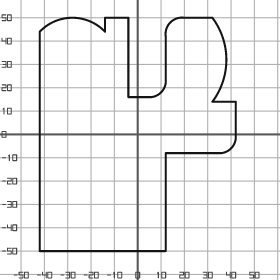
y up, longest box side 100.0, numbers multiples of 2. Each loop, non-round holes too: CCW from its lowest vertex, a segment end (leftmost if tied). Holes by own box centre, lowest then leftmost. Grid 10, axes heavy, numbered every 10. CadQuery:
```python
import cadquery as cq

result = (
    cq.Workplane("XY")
    .moveTo(-42.0, -50.0)
    .lineTo(12.0, -50.0)
    .lineTo(12.0, -8.0)
    .lineTo(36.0, -8.0)
    .threePointArc((40.0, -6.0), (42.0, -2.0))
    .lineTo(42.0, 14.0)
    .lineTo(32.0, 14.0)
    .threePointArc((38.0, 32.0), (32.0, 50.0))
    .lineTo(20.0, 50.0)
    .threePointArc((14.0, 48.0), (12.0, 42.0))
    .lineTo(12.0, 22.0)
    .threePointArc((10.0, 18.0), (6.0, 16.0))
    .lineTo(-4.0, 16.0)
    .lineTo(-4.0, 50.0)
    .lineTo(-14.0, 50.0)
    .lineTo(-14.0, 44.0)
    .threePointArc((-28.0, 50.0), (-42.0, 44.0))
    .close()
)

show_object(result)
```